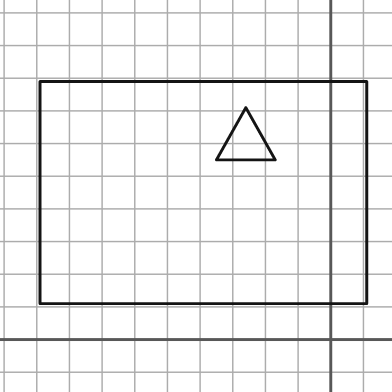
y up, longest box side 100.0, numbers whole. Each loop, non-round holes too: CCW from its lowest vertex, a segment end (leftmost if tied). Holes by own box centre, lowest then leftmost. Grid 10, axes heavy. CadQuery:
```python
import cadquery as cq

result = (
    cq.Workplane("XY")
    .moveTo(-89.0, 11.0)
    .lineTo(11.0, 11.0)
    .lineTo(11.0, 79.0)
    .lineTo(-89.0, 79.0)
    .close()
    .moveTo(-35.0, 55.0)
    .lineTo(-17.0, 55.0)
    .lineTo(-26.0, 71.0)
    .close()
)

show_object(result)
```